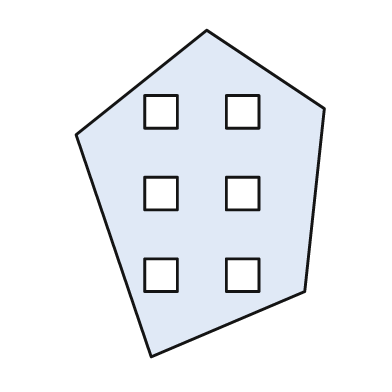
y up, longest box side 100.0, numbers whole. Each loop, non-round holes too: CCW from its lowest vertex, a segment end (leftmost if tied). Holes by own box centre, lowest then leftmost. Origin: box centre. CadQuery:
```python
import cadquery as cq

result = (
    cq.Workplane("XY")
    .moveTo(-15.0, -50.0)
    .lineTo(32.0, -30.0)
    .lineTo(38.0, 26.0)
    .lineTo(2.0, 50.0)
    .lineTo(-38.0, 18.0)
    .close()
    .moveTo(-17.0, -30.0)
    .lineTo(-7.0, -30.0)
    .lineTo(-7.0, -20.0)
    .lineTo(-17.0, -20.0)
    .close()
    .moveTo(8.0, -30.0)
    .lineTo(18.0, -30.0)
    .lineTo(18.0, -20.0)
    .lineTo(8.0, -20.0)
    .close()
    .moveTo(-17.0, -5.0)
    .lineTo(-7.0, -5.0)
    .lineTo(-7.0, 5.0)
    .lineTo(-17.0, 5.0)
    .close()
    .moveTo(8.0, -5.0)
    .lineTo(18.0, -5.0)
    .lineTo(18.0, 5.0)
    .lineTo(8.0, 5.0)
    .close()
    .moveTo(-17.0, 20.0)
    .lineTo(-7.0, 20.0)
    .lineTo(-7.0, 30.0)
    .lineTo(-17.0, 30.0)
    .close()
    .moveTo(8.0, 20.0)
    .lineTo(18.0, 20.0)
    .lineTo(18.0, 30.0)
    .lineTo(8.0, 30.0)
    .close()
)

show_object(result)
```